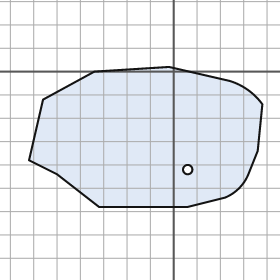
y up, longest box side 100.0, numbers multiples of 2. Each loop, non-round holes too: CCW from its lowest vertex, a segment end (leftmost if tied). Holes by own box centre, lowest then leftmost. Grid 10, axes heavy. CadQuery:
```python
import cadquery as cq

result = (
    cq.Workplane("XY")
    .moveTo(-32.0, -58.0)
    .lineTo(6.0, -58.0)
    .lineTo(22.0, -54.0)
    .threePointArc((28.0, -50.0), (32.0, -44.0))
    .lineTo(36.0, -34.0)
    .lineTo(38.0, -14.0)
    .threePointArc((32.0, -8.0), (24.0, -4.0))
    .lineTo(-2.0, 2.0)
    .lineTo(-34.0, 0.0)
    .lineTo(-56.0, -12.0)
    .lineTo(-62.0, -38.0)
    .lineTo(-50.0, -44.0)
    .close()
    .moveTo(6.0, -42.0)
    .circle(2.0)
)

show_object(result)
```